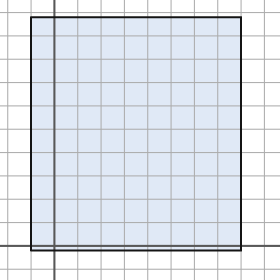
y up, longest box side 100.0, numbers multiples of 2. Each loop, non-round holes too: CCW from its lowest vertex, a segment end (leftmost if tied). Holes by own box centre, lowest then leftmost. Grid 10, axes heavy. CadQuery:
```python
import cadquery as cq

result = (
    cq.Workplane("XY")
    .moveTo(-10.0, -2.0)
    .lineTo(80.0, -2.0)
    .lineTo(80.0, 98.0)
    .lineTo(-10.0, 98.0)
    .close()
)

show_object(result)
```